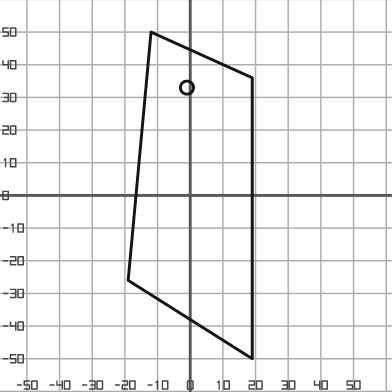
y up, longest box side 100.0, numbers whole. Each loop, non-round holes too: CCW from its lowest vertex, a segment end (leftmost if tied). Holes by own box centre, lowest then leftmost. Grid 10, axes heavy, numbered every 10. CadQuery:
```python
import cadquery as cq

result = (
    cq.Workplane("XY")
    .moveTo(19.0, -50.0)
    .lineTo(19.0, 36.0)
    .lineTo(-12.0, 50.0)
    .lineTo(-19.0, -26.0)
    .close()
    .moveTo(-1.0, 33.0)
    .circle(2.0)
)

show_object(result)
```